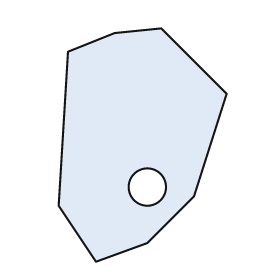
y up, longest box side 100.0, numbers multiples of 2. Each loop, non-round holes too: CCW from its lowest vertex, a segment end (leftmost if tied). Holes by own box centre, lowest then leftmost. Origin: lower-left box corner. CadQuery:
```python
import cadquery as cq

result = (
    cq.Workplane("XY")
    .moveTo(16.0, 0.0)
    .lineTo(38.0, 8.0)
    .lineTo(58.0, 28.0)
    .lineTo(72.0, 72.0)
    .lineTo(44.0, 100.0)
    .lineTo(24.0, 98.0)
    .lineTo(4.0, 90.0)
    .lineTo(0.0, 24.0)
    .close()
    .moveTo(38.0, 32.0)
    .circle(8.0)
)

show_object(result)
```